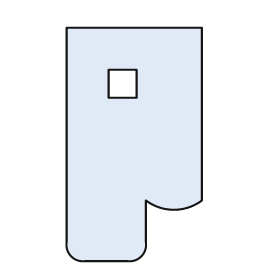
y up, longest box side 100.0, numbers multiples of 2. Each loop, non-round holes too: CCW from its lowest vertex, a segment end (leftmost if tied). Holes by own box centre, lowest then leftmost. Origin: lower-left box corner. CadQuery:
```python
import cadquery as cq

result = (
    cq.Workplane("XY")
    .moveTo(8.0, 0.0)
    .lineTo(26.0, 0.0)
    .threePointArc((32.0, 2.0), (34.0, 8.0))
    .lineTo(34.0, 26.0)
    .threePointArc((46.0, 22.0), (58.0, 26.0))
    .lineTo(58.0, 100.0)
    .lineTo(0.0, 100.0)
    .lineTo(0.0, 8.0)
    .threePointArc((2.0, 2.0), (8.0, 0.0))
    .close()
    .moveTo(18.0, 70.0)
    .lineTo(30.0, 70.0)
    .lineTo(30.0, 82.0)
    .lineTo(18.0, 82.0)
    .close()
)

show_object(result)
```